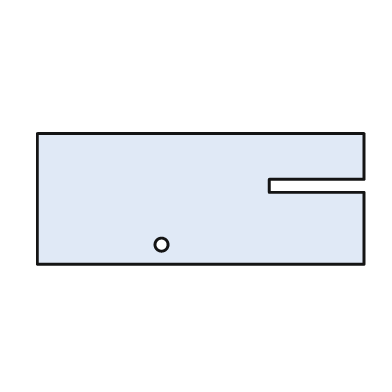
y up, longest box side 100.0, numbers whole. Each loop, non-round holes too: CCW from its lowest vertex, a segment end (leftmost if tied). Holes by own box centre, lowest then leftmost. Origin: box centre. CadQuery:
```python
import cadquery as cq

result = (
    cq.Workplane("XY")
    .moveTo(-50.0, -20.0)
    .lineTo(50.0, -20.0)
    .lineTo(50.0, 2.0)
    .lineTo(21.0, 2.0)
    .lineTo(21.0, 6.0)
    .lineTo(50.0, 6.0)
    .lineTo(50.0, 20.0)
    .lineTo(-50.0, 20.0)
    .close()
    .moveTo(-12.0, -14.0)
    .circle(2.0)
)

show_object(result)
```